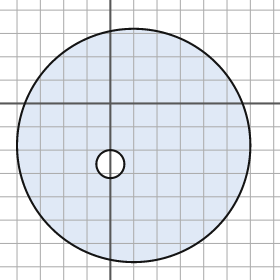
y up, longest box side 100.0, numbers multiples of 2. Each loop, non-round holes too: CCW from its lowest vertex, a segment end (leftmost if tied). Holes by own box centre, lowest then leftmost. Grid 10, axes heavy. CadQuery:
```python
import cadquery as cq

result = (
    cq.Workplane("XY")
    .moveTo(10.0, -18.0)
    .circle(50.0)
    .moveTo(0.0, -26.0)
    .circle(6.0)
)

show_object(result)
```